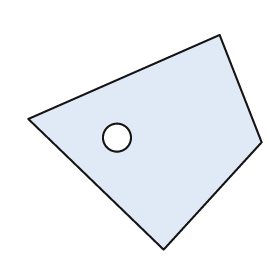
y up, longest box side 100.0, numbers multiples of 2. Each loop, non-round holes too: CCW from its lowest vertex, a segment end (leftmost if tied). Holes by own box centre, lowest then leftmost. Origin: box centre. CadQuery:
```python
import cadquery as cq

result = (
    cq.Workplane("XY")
    .moveTo(8.0, -46.0)
    .lineTo(50.0, 0.0)
    .lineTo(32.0, 46.0)
    .lineTo(-50.0, 10.0)
    .close()
    .moveTo(-12.0, 2.0)
    .circle(6.0)
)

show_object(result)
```